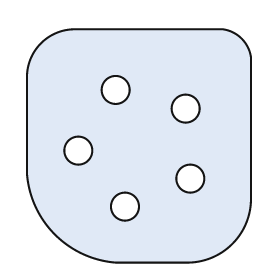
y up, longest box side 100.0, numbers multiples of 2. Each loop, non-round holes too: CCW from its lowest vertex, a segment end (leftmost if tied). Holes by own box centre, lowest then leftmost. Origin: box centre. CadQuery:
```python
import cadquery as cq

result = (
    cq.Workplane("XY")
    .moveTo(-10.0, -50.0)
    .lineTo(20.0, -50.0)
    .threePointArc((40.0, -42.0), (48.0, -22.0))
    .lineTo(48.0, 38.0)
    .threePointArc((44.0, 46.0), (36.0, 50.0))
    .lineTo(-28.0, 50.0)
    .threePointArc((-42.0, 44.0), (-48.0, 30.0))
    .lineTo(-48.0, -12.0)
    .threePointArc((-36.0, -38.0), (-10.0, -50.0))
    .close()
    .moveTo(-6.0, -26.0)
    .circle(6.0)
    .moveTo(22.0, -14.0)
    .circle(6.0)
    .moveTo(-26.0, -2.0)
    .circle(6.0)
    .moveTo(20.0, 16.0)
    .circle(6.0)
    .moveTo(-10.0, 24.0)
    .circle(6.0)
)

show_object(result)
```